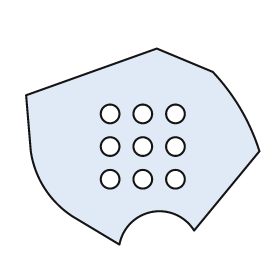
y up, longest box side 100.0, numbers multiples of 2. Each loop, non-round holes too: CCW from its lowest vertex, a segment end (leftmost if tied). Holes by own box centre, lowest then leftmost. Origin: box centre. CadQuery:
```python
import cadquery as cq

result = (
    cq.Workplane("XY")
    .moveTo(-10.0, -42.0)
    .threePointArc((4.0, -28.0), (22.0, -36.0))
    .lineTo(50.0, -2.0)
    .threePointArc((42.0, 16.0), (30.0, 32.0))
    .lineTo(6.0, 42.0)
    .lineTo(-50.0, 22.0)
    .lineTo(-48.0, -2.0)
    .threePointArc((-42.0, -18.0), (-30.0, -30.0))
    .close()
    .moveTo(-14.0, -14.0)
    .circle(4.0)
    .moveTo(0.0, -14.0)
    .circle(4.0)
    .moveTo(14.0, -14.0)
    .circle(4.0)
    .moveTo(-14.0, 0.0)
    .circle(4.0)
    .moveTo(0.0, 0.0)
    .circle(4.0)
    .moveTo(14.0, 0.0)
    .circle(4.0)
    .moveTo(-14.0, 14.0)
    .circle(4.0)
    .moveTo(0.0, 14.0)
    .circle(4.0)
    .moveTo(14.0, 14.0)
    .circle(4.0)
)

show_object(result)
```